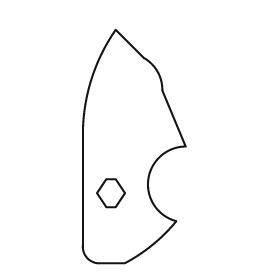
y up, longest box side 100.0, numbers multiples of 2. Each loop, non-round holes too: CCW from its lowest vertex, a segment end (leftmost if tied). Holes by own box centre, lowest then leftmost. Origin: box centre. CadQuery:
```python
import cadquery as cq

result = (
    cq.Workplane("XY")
    .moveTo(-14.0, -50.0)
    .lineTo(-4.0, -50.0)
    .threePointArc((8.0, -42.0), (18.0, -32.0))
    .threePointArc((6.0, -14.0), (22.0, 0.0))
    .lineTo(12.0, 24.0)
    .threePointArc((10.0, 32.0), (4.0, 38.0))
    .lineTo(-8.0, 50.0)
    .threePointArc((-18.0, 30.0), (-22.0, 8.0))
    .lineTo(-22.0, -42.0)
    .threePointArc((-20.0, -48.0), (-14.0, -50.0))
    .close()
    .moveTo(-12.0, -26.0)
    .lineTo(-8.0, -26.0)
    .lineTo(-4.0, -20.0)
    .lineTo(-8.0, -14.0)
    .lineTo(-12.0, -14.0)
    .lineTo(-16.0, -20.0)
    .close()
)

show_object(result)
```